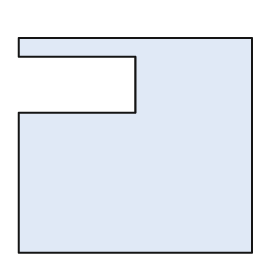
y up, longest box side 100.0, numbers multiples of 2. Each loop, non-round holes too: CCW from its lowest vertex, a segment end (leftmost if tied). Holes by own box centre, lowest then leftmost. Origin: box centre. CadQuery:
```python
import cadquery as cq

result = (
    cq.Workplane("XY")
    .moveTo(-50.0, -46.0)
    .lineTo(50.0, -46.0)
    .lineTo(50.0, 46.0)
    .lineTo(-50.0, 46.0)
    .lineTo(-50.0, 38.0)
    .lineTo(0.0, 38.0)
    .lineTo(0.0, 14.0)
    .lineTo(-50.0, 14.0)
    .close()
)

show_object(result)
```